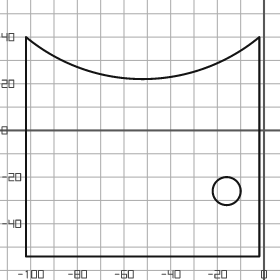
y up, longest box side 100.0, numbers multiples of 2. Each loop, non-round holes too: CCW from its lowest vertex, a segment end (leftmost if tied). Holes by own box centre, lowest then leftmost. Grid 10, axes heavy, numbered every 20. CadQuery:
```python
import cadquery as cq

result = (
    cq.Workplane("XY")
    .moveTo(-102.0, -54.0)
    .lineTo(-2.0, -54.0)
    .lineTo(-2.0, 40.0)
    .threePointArc((-52.0, 22.0), (-102.0, 40.0))
    .close()
    .moveTo(-16.0, -26.0)
    .circle(6.0)
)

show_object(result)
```